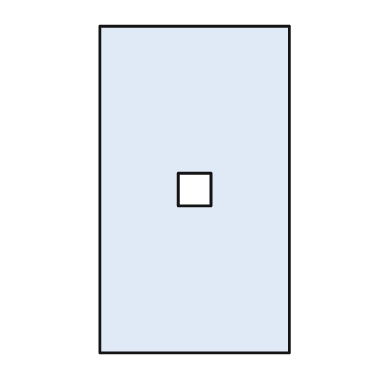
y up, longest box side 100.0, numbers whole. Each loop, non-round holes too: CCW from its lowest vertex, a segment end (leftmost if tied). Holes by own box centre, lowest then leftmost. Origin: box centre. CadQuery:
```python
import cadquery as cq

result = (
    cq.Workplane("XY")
    .moveTo(-29.0, -50.0)
    .lineTo(29.0, -50.0)
    .lineTo(29.0, 50.0)
    .lineTo(-29.0, 50.0)
    .close()
    .moveTo(-5.0, -5.0)
    .lineTo(5.0, -5.0)
    .lineTo(5.0, 5.0)
    .lineTo(-5.0, 5.0)
    .close()
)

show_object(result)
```